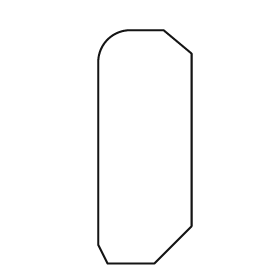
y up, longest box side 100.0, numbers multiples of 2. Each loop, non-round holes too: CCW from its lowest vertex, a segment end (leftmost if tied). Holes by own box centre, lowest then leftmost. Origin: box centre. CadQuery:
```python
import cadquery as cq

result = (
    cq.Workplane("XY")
    .moveTo(-16.0, -50.0)
    .lineTo(4.0, -50.0)
    .lineTo(20.0, -34.0)
    .lineTo(20.0, 40.0)
    .lineTo(8.0, 50.0)
    .lineTo(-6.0, 50.0)
    .threePointArc((-16.0, 46.0), (-20.0, 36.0))
    .lineTo(-20.0, -42.0)
    .close()
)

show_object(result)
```